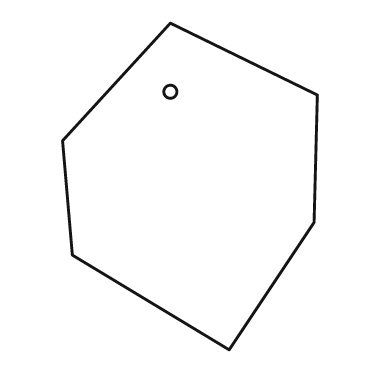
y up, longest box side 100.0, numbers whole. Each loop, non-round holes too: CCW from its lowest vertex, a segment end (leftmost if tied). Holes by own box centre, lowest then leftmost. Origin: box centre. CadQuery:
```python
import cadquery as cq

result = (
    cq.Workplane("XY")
    .moveTo(12.0, -50.0)
    .lineTo(38.0, -11.0)
    .lineTo(39.0, 28.0)
    .lineTo(-6.0, 50.0)
    .lineTo(-39.0, 14.0)
    .lineTo(-36.0, -21.0)
    .close()
    .moveTo(-6.0, 29.0)
    .circle(2.0)
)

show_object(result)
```